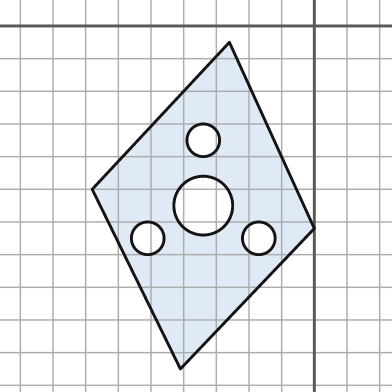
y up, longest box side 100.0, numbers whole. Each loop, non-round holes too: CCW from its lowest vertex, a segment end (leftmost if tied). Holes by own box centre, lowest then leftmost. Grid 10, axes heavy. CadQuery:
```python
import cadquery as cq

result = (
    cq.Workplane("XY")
    .moveTo(-41.0, -105.0)
    .lineTo(0.0, -62.0)
    .lineTo(-26.0, -5.0)
    .lineTo(-68.0, -50.0)
    .close()
    .moveTo(-51.0, -65.0)
    .circle(5.0)
    .moveTo(-17.0, -65.0)
    .circle(5.0)
    .moveTo(-34.0, -55.0)
    .circle(9.0)
    .moveTo(-34.0, -35.0)
    .circle(5.0)
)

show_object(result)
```